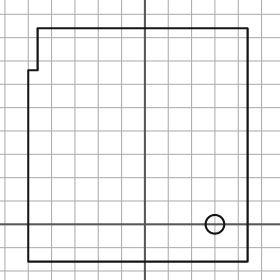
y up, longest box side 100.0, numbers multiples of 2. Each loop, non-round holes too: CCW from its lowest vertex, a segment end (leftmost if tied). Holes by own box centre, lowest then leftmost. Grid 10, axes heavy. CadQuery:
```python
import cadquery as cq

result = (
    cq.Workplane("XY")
    .moveTo(-50.0, -16.0)
    .lineTo(44.0, -16.0)
    .lineTo(44.0, 84.0)
    .lineTo(-46.0, 84.0)
    .lineTo(-46.0, 66.0)
    .lineTo(-50.0, 66.0)
    .close()
    .moveTo(30.0, 0.0)
    .circle(4.0)
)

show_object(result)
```